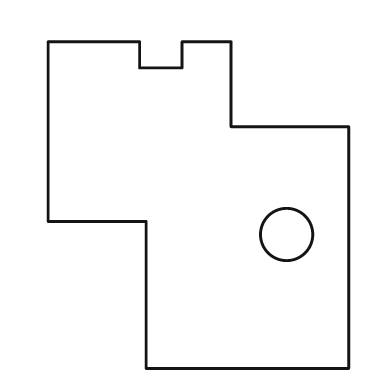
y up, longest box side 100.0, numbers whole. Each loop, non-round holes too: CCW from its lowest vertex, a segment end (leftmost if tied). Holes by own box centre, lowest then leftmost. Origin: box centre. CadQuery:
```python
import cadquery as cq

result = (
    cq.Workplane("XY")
    .moveTo(-16.0, -50.0)
    .lineTo(46.0, -50.0)
    .lineTo(46.0, 24.0)
    .lineTo(10.0, 24.0)
    .lineTo(10.0, 50.0)
    .lineTo(-5.0, 50.0)
    .lineTo(-5.0, 42.0)
    .lineTo(-18.0, 42.0)
    .lineTo(-18.0, 50.0)
    .lineTo(-46.0, 50.0)
    .lineTo(-46.0, -5.0)
    .lineTo(-16.0, -5.0)
    .close()
    .moveTo(27.0, -9.0)
    .circle(8.0)
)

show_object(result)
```